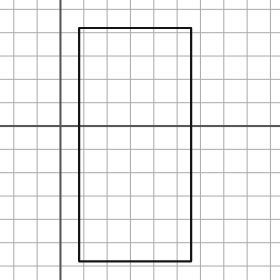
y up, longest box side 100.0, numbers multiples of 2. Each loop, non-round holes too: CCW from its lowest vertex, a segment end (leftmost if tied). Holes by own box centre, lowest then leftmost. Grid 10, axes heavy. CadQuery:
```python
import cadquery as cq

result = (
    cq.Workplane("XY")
    .moveTo(8.0, -58.0)
    .lineTo(56.0, -58.0)
    .lineTo(56.0, 42.0)
    .lineTo(8.0, 42.0)
    .close()
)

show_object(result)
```